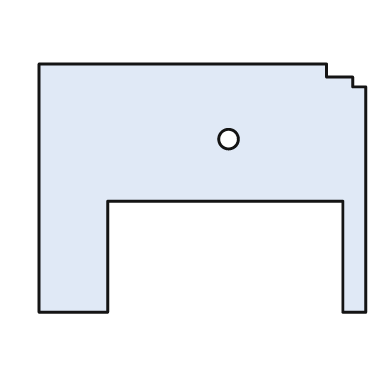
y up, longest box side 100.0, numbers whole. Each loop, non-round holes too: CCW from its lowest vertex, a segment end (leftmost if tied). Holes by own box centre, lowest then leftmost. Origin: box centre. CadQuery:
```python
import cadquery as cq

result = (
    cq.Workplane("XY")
    .moveTo(-50.0, -38.0)
    .lineTo(-29.0, -38.0)
    .lineTo(-29.0, -4.0)
    .lineTo(43.0, -4.0)
    .lineTo(43.0, -38.0)
    .lineTo(50.0, -38.0)
    .lineTo(50.0, 31.0)
    .lineTo(46.0, 31.0)
    .lineTo(46.0, 34.0)
    .lineTo(38.0, 34.0)
    .lineTo(38.0, 38.0)
    .lineTo(-50.0, 38.0)
    .close()
    .moveTo(8.0, 15.0)
    .circle(3.0)
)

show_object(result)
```